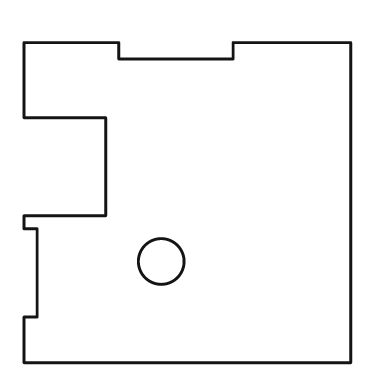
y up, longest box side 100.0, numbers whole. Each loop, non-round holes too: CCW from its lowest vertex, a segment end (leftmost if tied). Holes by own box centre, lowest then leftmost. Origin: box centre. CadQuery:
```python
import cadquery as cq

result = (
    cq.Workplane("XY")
    .moveTo(-50.0, -49.0)
    .lineTo(50.0, -49.0)
    .lineTo(50.0, 49.0)
    .lineTo(14.0, 49.0)
    .lineTo(14.0, 44.0)
    .lineTo(-21.0, 44.0)
    .lineTo(-21.0, 49.0)
    .lineTo(-50.0, 49.0)
    .lineTo(-50.0, 26.0)
    .lineTo(-25.0, 26.0)
    .lineTo(-25.0, -4.0)
    .lineTo(-50.0, -4.0)
    .lineTo(-50.0, -8.0)
    .lineTo(-46.0, -8.0)
    .lineTo(-46.0, -35.0)
    .lineTo(-50.0, -35.0)
    .close()
    .moveTo(-8.0, -18.0)
    .circle(7.0)
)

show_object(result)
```